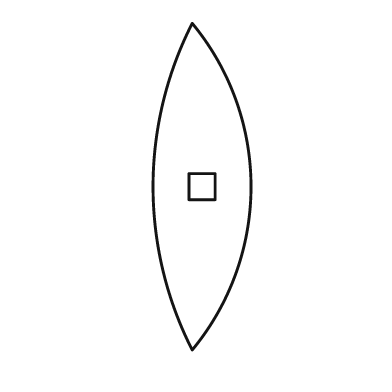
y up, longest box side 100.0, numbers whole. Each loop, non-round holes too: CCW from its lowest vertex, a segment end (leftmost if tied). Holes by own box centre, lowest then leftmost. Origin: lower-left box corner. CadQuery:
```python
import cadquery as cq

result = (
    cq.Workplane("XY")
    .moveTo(12.0, 0.0)
    .threePointArc((30.0, 50.0), (12.0, 100.0))
    .threePointArc((0.0, 50.0), (12.0, 0.0))
    .close()
    .moveTo(11.0, 46.0)
    .lineTo(19.0, 46.0)
    .lineTo(19.0, 54.0)
    .lineTo(11.0, 54.0)
    .close()
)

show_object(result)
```